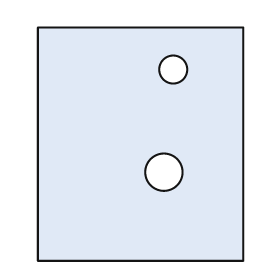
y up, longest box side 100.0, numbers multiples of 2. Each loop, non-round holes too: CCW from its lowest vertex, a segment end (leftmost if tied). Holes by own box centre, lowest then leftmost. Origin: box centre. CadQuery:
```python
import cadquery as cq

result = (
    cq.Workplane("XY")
    .moveTo(-44.0, -50.0)
    .lineTo(44.0, -50.0)
    .lineTo(44.0, 50.0)
    .lineTo(-44.0, 50.0)
    .close()
    .moveTo(10.0, -12.0)
    .circle(8.0)
    .moveTo(14.0, 32.0)
    .circle(6.0)
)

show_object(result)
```